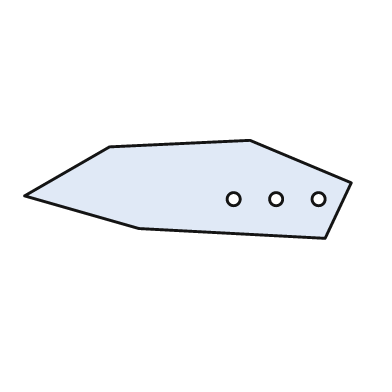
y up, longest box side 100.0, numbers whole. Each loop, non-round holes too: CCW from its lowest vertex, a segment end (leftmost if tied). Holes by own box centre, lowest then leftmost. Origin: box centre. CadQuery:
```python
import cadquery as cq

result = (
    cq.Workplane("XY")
    .moveTo(42.0, -15.0)
    .lineTo(50.0, 2.0)
    .lineTo(19.0, 15.0)
    .lineTo(-24.0, 13.0)
    .lineTo(-50.0, -2.0)
    .lineTo(-15.0, -12.0)
    .close()
    .moveTo(14.0, -3.0)
    .circle(2.0)
    .moveTo(27.0, -3.0)
    .circle(2.0)
    .moveTo(40.0, -3.0)
    .circle(2.0)
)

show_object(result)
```